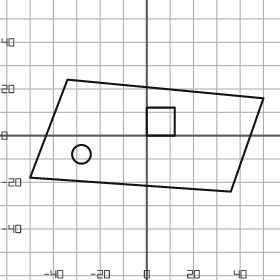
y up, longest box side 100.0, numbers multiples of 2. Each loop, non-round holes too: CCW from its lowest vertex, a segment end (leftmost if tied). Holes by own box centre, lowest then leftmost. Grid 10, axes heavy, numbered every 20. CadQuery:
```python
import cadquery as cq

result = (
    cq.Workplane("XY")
    .moveTo(36.0, -24.0)
    .lineTo(50.0, 16.0)
    .lineTo(-34.0, 24.0)
    .lineTo(-50.0, -18.0)
    .close()
    .moveTo(-28.0, -8.0)
    .circle(4.0)
    .moveTo(0.0, 0.0)
    .lineTo(12.0, 0.0)
    .lineTo(12.0, 12.0)
    .lineTo(0.0, 12.0)
    .close()
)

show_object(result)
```